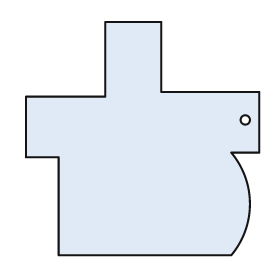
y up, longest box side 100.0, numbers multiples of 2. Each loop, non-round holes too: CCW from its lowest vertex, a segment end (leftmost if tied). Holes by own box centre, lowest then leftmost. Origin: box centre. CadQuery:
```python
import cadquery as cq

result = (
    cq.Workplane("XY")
    .moveTo(-36.0, -50.0)
    .lineTo(38.0, -50.0)
    .threePointArc((46.0, -28.0), (38.0, -6.0))
    .lineTo(50.0, -6.0)
    .lineTo(50.0, 20.0)
    .lineTo(8.0, 20.0)
    .lineTo(8.0, 50.0)
    .lineTo(-16.0, 50.0)
    .lineTo(-16.0, 18.0)
    .lineTo(-50.0, 18.0)
    .lineTo(-50.0, -8.0)
    .lineTo(-36.0, -8.0)
    .close()
    .moveTo(44.0, 8.0)
    .circle(2.0)
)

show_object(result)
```